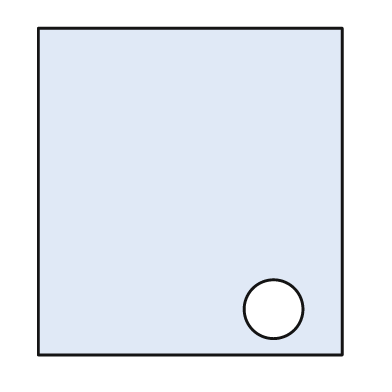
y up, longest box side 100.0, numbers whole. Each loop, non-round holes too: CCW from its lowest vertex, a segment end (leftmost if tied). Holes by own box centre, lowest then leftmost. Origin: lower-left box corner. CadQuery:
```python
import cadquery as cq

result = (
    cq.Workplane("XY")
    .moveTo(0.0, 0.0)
    .lineTo(93.0, 0.0)
    .lineTo(93.0, 100.0)
    .lineTo(0.0, 100.0)
    .close()
    .moveTo(72.0, 14.0)
    .circle(9.0)
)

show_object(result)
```